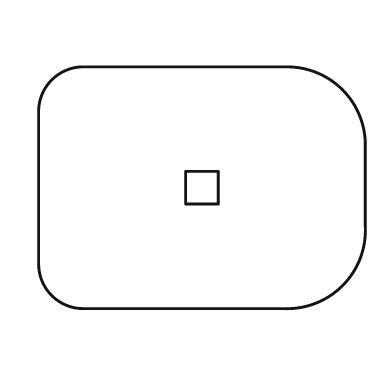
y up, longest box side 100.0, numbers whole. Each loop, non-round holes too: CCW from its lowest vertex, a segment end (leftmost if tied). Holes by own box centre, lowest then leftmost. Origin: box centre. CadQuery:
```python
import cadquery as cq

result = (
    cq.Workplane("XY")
    .moveTo(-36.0, -37.0)
    .lineTo(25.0, -37.0)
    .threePointArc((43.0, -30.0), (50.0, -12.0))
    .lineTo(50.0, 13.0)
    .threePointArc((43.0, 30.0), (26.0, 37.0))
    .lineTo(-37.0, 37.0)
    .threePointArc((-46.0, 33.0), (-50.0, 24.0))
    .lineTo(-50.0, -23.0)
    .threePointArc((-46.0, -33.0), (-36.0, -37.0))
    .close()
    .moveTo(-5.0, -5.0)
    .lineTo(5.0, -5.0)
    .lineTo(5.0, 5.0)
    .lineTo(-5.0, 5.0)
    .close()
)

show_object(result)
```